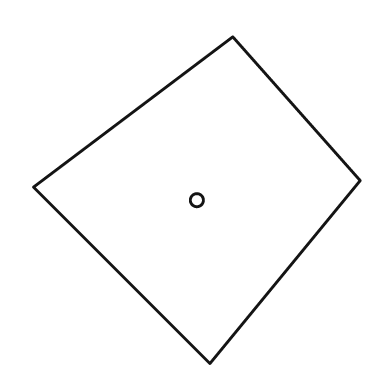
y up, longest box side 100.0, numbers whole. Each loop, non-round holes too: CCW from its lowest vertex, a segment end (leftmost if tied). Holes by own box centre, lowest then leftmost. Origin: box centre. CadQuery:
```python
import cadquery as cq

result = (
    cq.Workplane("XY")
    .moveTo(4.0, -50.0)
    .lineTo(50.0, 6.0)
    .lineTo(11.0, 50.0)
    .lineTo(-50.0, 4.0)
    .close()
    .moveTo(0.0, 0.0)
    .circle(2.0)
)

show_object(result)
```